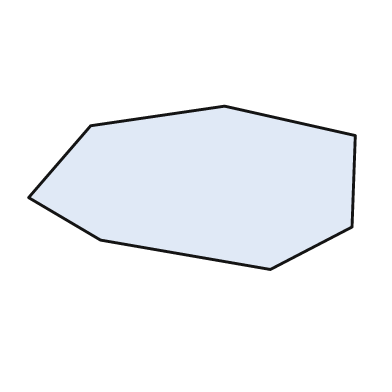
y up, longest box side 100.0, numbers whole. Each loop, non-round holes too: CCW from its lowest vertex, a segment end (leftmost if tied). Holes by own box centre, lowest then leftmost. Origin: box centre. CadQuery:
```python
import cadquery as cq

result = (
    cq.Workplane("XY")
    .moveTo(24.0, -25.0)
    .lineTo(49.0, -12.0)
    .lineTo(50.0, 16.0)
    .lineTo(10.0, 25.0)
    .lineTo(-31.0, 19.0)
    .lineTo(-50.0, -3.0)
    .lineTo(-28.0, -16.0)
    .close()
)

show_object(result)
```